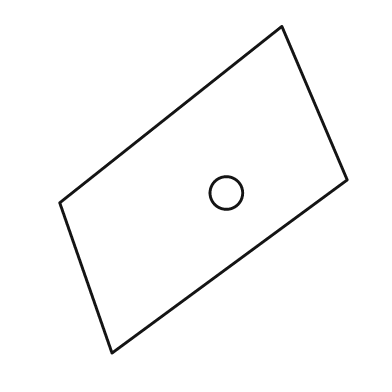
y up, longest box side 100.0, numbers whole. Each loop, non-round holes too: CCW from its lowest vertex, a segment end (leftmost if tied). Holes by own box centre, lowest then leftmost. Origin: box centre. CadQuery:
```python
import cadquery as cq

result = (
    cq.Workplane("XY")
    .moveTo(-28.0, -50.0)
    .lineTo(44.0, 3.0)
    .lineTo(24.0, 50.0)
    .lineTo(-44.0, -4.0)
    .close()
    .moveTo(7.0, -1.0)
    .circle(5.0)
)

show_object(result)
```